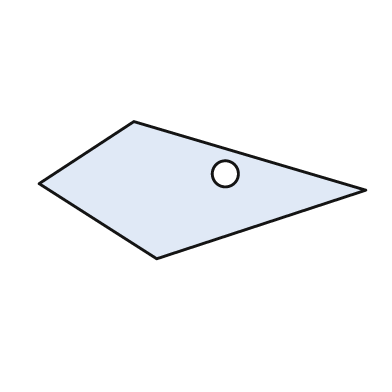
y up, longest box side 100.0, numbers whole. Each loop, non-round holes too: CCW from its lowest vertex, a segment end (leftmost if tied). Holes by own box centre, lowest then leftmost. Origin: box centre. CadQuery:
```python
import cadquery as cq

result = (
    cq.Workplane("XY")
    .moveTo(-14.0, -21.0)
    .lineTo(50.0, 0.0)
    .lineTo(-21.0, 21.0)
    .lineTo(-50.0, 2.0)
    .close()
    .moveTo(7.0, 5.0)
    .circle(4.0)
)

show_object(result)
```